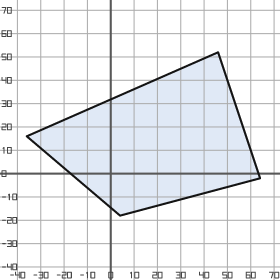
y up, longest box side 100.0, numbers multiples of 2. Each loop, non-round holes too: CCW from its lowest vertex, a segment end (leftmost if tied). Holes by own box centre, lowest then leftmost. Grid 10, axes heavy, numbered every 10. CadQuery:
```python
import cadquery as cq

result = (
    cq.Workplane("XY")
    .moveTo(4.0, -18.0)
    .lineTo(64.0, -2.0)
    .lineTo(46.0, 52.0)
    .lineTo(-36.0, 16.0)
    .close()
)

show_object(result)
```